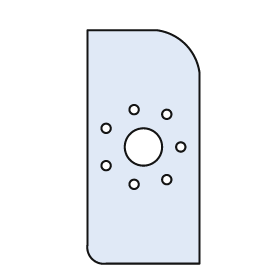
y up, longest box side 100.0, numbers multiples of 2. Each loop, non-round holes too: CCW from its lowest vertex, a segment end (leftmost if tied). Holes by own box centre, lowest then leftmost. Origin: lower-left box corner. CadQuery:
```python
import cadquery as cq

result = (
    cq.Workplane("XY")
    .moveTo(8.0, 0.0)
    .lineTo(48.0, 0.0)
    .lineTo(48.0, 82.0)
    .threePointArc((42.0, 94.0), (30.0, 100.0))
    .lineTo(0.0, 100.0)
    .lineTo(0.0, 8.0)
    .threePointArc((2.0, 2.0), (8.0, 0.0))
    .close()
    .moveTo(20.0, 34.0)
    .circle(2.0)
    .moveTo(34.0, 36.0)
    .circle(2.0)
    .moveTo(8.0, 42.0)
    .circle(2.0)
    .moveTo(24.0, 50.0)
    .circle(8.0)
    .moveTo(40.0, 50.0)
    .circle(2.0)
    .moveTo(8.0, 58.0)
    .circle(2.0)
    .moveTo(34.0, 64.0)
    .circle(2.0)
    .moveTo(20.0, 66.0)
    .circle(2.0)
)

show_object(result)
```